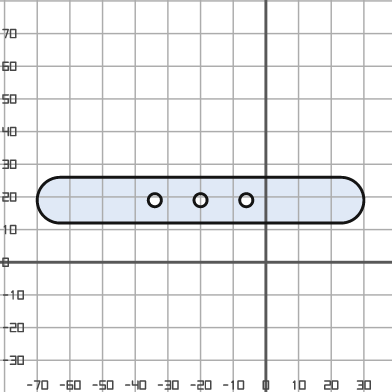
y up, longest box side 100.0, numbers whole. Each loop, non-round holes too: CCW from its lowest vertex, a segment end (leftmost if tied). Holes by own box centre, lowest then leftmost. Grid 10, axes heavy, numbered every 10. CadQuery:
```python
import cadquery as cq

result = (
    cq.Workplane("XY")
    .moveTo(-63.0, 12.0)
    .lineTo(23.0, 12.0)
    .threePointArc((30.0, 19.0), (23.0, 26.0))
    .lineTo(-63.0, 26.0)
    .threePointArc((-70.0, 19.0), (-63.0, 12.0))
    .close()
    .moveTo(-34.0, 19.0)
    .circle(2.0)
    .moveTo(-20.0, 19.0)
    .circle(2.0)
    .moveTo(-6.0, 19.0)
    .circle(2.0)
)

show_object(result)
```